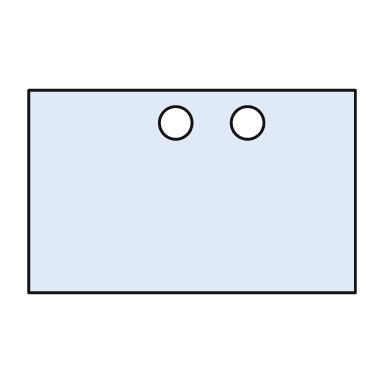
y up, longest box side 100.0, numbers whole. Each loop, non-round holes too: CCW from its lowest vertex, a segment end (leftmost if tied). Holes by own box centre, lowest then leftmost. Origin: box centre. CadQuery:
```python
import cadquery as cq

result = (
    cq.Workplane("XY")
    .moveTo(-50.0, -31.0)
    .lineTo(50.0, -31.0)
    .lineTo(50.0, 31.0)
    .lineTo(-50.0, 31.0)
    .close()
    .moveTo(-5.0, 21.0)
    .circle(5.0)
    .moveTo(17.0, 21.0)
    .circle(5.0)
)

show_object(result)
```